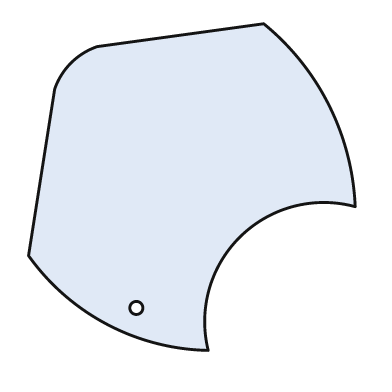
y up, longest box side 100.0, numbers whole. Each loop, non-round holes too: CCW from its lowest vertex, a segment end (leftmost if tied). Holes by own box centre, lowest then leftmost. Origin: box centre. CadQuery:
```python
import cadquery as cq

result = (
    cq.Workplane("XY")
    .moveTo(5.0, -50.0)
    .threePointArc((15.0, -15.0), (50.0, -6.0))
    .threePointArc((42.0, 25.0), (22.0, 50.0))
    .lineTo(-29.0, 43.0)
    .threePointArc((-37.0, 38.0), (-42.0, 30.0))
    .lineTo(-50.0, -21.0)
    .threePointArc((-26.0, -42.0), (5.0, -50.0))
    .close()
    .moveTo(-17.0, -37.0)
    .circle(2.0)
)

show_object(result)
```